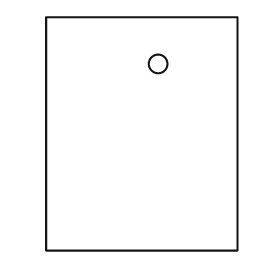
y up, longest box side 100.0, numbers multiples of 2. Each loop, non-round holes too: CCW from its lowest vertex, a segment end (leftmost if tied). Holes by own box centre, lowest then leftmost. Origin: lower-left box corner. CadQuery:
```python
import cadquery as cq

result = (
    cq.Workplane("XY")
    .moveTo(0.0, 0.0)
    .lineTo(82.0, 0.0)
    .lineTo(82.0, 100.0)
    .lineTo(0.0, 100.0)
    .close()
    .moveTo(48.0, 80.0)
    .circle(4.0)
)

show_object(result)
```